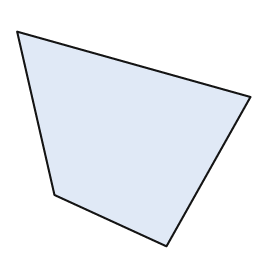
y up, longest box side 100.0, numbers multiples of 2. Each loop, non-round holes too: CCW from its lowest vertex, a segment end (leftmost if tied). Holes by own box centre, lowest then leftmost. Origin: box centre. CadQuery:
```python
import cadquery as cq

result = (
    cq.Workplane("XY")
    .moveTo(14.0, -46.0)
    .lineTo(50.0, 18.0)
    .lineTo(-50.0, 46.0)
    .lineTo(-34.0, -24.0)
    .close()
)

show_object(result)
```